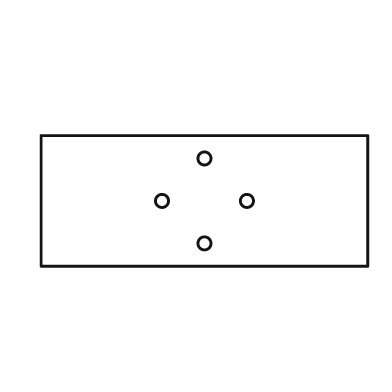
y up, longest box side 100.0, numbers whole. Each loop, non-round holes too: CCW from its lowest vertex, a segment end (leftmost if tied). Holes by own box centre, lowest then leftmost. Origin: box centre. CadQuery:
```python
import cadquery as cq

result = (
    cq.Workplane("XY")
    .moveTo(-50.0, -20.0)
    .lineTo(50.0, -20.0)
    .lineTo(50.0, 20.0)
    .lineTo(-50.0, 20.0)
    .close()
    .moveTo(0.0, -13.0)
    .circle(2.0)
    .moveTo(-13.0, 0.0)
    .circle(2.0)
    .moveTo(13.0, 0.0)
    .circle(2.0)
    .moveTo(0.0, 13.0)
    .circle(2.0)
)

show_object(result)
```